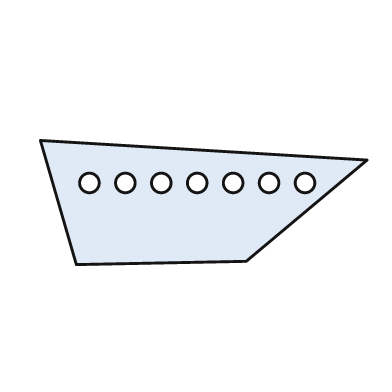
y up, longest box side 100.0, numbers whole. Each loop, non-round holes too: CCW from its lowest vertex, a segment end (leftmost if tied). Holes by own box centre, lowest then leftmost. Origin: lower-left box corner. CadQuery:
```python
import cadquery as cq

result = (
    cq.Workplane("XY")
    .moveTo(11.0, 0.0)
    .lineTo(63.0, 1.0)
    .lineTo(100.0, 32.0)
    .lineTo(0.0, 38.0)
    .close()
    .moveTo(15.0, 25.0)
    .circle(3.0)
    .moveTo(26.0, 25.0)
    .circle(3.0)
    .moveTo(37.0, 25.0)
    .circle(3.0)
    .moveTo(48.0, 25.0)
    .circle(3.0)
    .moveTo(59.0, 25.0)
    .circle(3.0)
    .moveTo(70.0, 25.0)
    .circle(3.0)
    .moveTo(81.0, 25.0)
    .circle(3.0)
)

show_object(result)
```